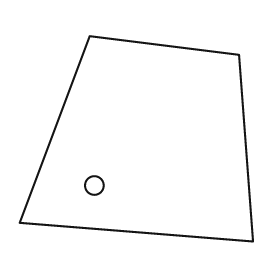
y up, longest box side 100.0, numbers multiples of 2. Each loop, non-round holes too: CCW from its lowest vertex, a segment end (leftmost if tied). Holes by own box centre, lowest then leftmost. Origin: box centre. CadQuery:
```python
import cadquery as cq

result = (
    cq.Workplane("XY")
    .moveTo(50.0, -44.0)
    .lineTo(44.0, 36.0)
    .lineTo(-20.0, 44.0)
    .lineTo(-50.0, -36.0)
    .close()
    .moveTo(-18.0, -20.0)
    .circle(4.0)
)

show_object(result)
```